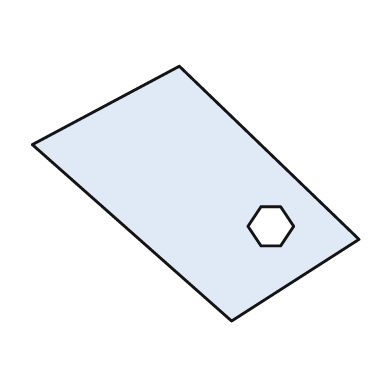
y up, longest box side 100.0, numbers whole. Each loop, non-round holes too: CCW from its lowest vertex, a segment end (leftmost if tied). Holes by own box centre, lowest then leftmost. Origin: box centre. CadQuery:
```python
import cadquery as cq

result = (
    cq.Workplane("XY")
    .moveTo(11.0, -39.0)
    .lineTo(50.0, -14.0)
    .lineTo(-5.0, 39.0)
    .lineTo(-50.0, 15.0)
    .close()
    .moveTo(20.0, -16.0)
    .lineTo(26.0, -16.0)
    .lineTo(30.0, -10.0)
    .lineTo(26.0, -4.0)
    .lineTo(20.0, -4.0)
    .lineTo(16.0, -10.0)
    .close()
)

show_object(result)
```